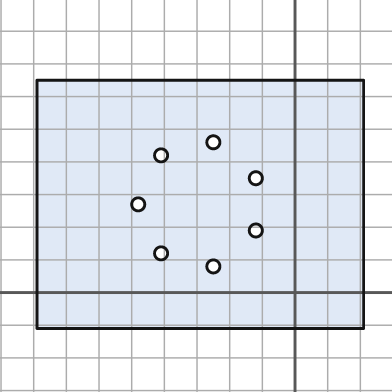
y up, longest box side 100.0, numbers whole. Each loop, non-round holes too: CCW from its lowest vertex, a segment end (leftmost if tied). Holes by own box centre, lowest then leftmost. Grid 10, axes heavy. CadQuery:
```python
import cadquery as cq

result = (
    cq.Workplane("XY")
    .moveTo(-79.0, -11.0)
    .lineTo(21.0, -11.0)
    .lineTo(21.0, 65.0)
    .lineTo(-79.0, 65.0)
    .close()
    .moveTo(-25.0, 8.0)
    .circle(2.0)
    .moveTo(-41.0, 12.0)
    .circle(2.0)
    .moveTo(-12.0, 19.0)
    .circle(2.0)
    .moveTo(-48.0, 27.0)
    .circle(2.0)
    .moveTo(-12.0, 35.0)
    .circle(2.0)
    .moveTo(-41.0, 42.0)
    .circle(2.0)
    .moveTo(-25.0, 46.0)
    .circle(2.0)
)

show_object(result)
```